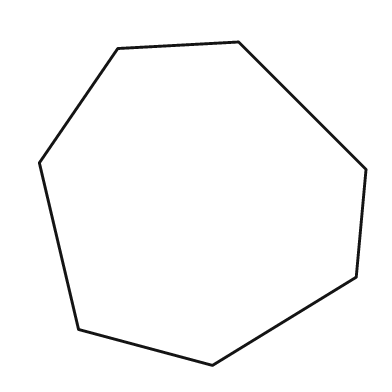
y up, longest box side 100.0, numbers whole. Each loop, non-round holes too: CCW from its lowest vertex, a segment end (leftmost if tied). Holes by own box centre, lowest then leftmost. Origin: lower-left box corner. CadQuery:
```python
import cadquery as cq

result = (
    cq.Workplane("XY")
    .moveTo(53.0, 0.0)
    .lineTo(97.0, 27.0)
    .lineTo(100.0, 60.0)
    .lineTo(61.0, 99.0)
    .lineTo(24.0, 97.0)
    .lineTo(0.0, 62.0)
    .lineTo(12.0, 11.0)
    .close()
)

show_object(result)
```